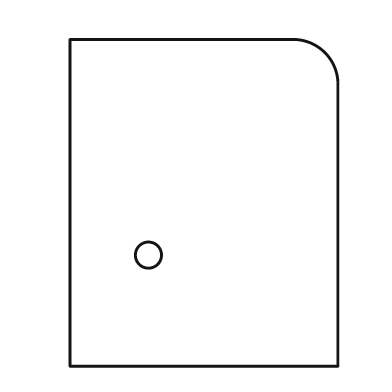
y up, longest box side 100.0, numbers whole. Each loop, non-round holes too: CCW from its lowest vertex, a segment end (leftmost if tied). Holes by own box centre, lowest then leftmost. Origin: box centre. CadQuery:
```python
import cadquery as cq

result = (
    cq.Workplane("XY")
    .moveTo(-41.0, -50.0)
    .lineTo(41.0, -50.0)
    .lineTo(41.0, 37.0)
    .threePointArc((37.0, 46.0), (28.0, 50.0))
    .lineTo(-41.0, 50.0)
    .close()
    .moveTo(-17.0, -16.0)
    .circle(4.0)
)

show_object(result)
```